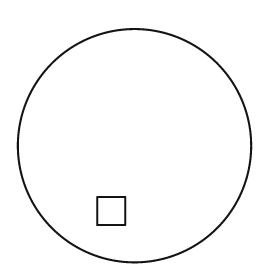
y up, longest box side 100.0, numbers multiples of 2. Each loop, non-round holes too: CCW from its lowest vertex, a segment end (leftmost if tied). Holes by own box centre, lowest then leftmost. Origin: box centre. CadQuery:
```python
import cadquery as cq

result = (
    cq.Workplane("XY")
    .moveTo(0.0, 0.0)
    .circle(50.0)
    .moveTo(-16.0, -34.0)
    .lineTo(-4.0, -34.0)
    .lineTo(-4.0, -22.0)
    .lineTo(-16.0, -22.0)
    .close()
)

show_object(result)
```